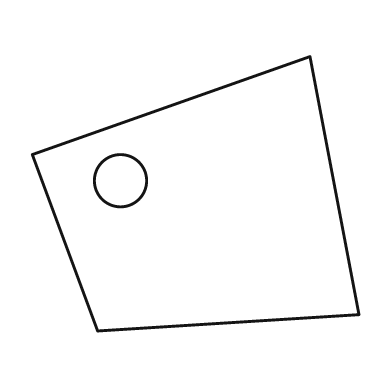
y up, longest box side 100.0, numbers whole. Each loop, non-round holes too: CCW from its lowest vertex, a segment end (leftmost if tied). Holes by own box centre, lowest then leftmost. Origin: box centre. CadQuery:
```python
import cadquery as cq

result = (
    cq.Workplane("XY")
    .moveTo(-30.0, -42.0)
    .lineTo(50.0, -37.0)
    .lineTo(35.0, 42.0)
    .lineTo(-50.0, 12.0)
    .close()
    .moveTo(-23.0, 4.0)
    .circle(8.0)
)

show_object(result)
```